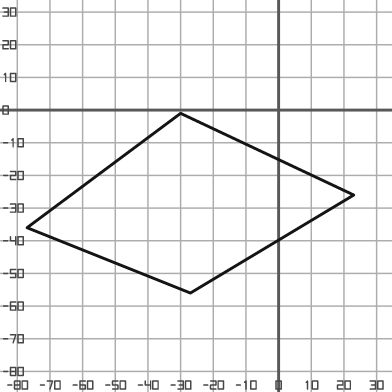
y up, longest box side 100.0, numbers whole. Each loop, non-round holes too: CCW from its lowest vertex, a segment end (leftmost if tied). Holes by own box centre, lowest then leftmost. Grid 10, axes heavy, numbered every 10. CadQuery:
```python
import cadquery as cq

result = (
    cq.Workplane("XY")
    .moveTo(-27.0, -56.0)
    .lineTo(23.0, -26.0)
    .lineTo(-30.0, -1.0)
    .lineTo(-77.0, -36.0)
    .close()
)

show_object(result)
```